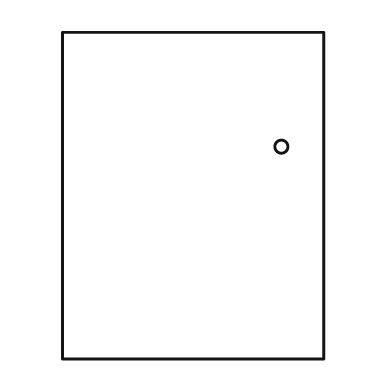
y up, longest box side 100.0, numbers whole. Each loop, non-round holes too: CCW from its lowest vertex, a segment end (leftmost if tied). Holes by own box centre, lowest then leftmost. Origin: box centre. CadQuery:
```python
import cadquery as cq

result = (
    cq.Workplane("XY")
    .moveTo(-40.0, -50.0)
    .lineTo(40.0, -50.0)
    .lineTo(40.0, 50.0)
    .lineTo(-40.0, 50.0)
    .close()
    .moveTo(27.0, 15.0)
    .circle(2.0)
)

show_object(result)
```